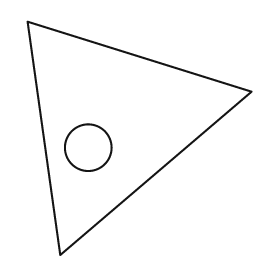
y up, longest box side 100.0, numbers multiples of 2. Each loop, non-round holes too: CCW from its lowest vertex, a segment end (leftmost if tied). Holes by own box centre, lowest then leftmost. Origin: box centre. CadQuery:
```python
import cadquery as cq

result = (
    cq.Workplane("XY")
    .moveTo(-34.0, -50.0)
    .lineTo(48.0, 20.0)
    .lineTo(-48.0, 50.0)
    .close()
    .moveTo(-22.0, -4.0)
    .circle(10.0)
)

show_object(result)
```